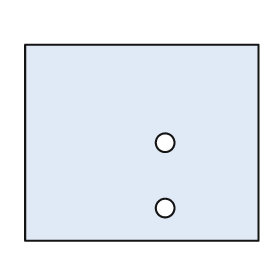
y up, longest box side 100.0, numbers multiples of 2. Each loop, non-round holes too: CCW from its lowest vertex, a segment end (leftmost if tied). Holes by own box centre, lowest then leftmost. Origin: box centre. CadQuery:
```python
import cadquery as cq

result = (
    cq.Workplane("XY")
    .moveTo(-50.0, -42.0)
    .lineTo(50.0, -42.0)
    .lineTo(50.0, 42.0)
    .lineTo(-50.0, 42.0)
    .close()
    .moveTo(10.0, -28.0)
    .circle(4.0)
    .moveTo(10.0, 0.0)
    .circle(4.0)
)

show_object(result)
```